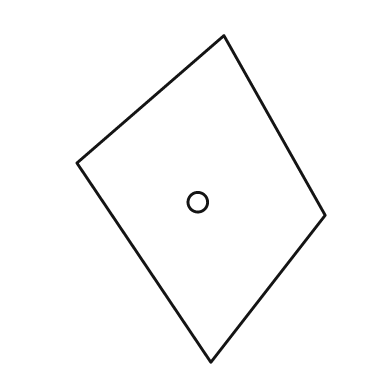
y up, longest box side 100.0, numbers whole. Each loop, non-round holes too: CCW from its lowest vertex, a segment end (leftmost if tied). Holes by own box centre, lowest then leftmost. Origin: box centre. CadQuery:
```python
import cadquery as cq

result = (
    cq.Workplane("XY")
    .moveTo(3.0, -50.0)
    .lineTo(38.0, -5.0)
    .lineTo(7.0, 50.0)
    .lineTo(-38.0, 11.0)
    .close()
    .moveTo(-1.0, -1.0)
    .circle(3.0)
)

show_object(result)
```